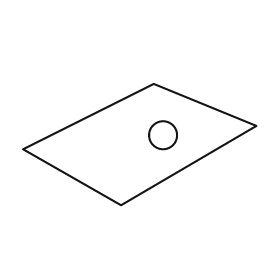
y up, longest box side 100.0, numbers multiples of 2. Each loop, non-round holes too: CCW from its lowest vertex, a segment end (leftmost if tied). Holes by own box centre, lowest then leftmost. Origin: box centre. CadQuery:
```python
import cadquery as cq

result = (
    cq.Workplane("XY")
    .moveTo(-8.0, -26.0)
    .lineTo(50.0, 8.0)
    .lineTo(6.0, 26.0)
    .lineTo(-50.0, -2.0)
    .close()
    .moveTo(10.0, 4.0)
    .circle(6.0)
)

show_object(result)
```